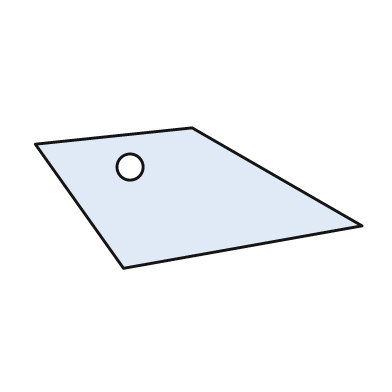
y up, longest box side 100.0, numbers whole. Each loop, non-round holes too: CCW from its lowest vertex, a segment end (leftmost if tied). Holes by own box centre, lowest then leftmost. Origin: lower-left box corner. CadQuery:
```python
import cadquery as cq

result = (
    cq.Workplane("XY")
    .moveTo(27.0, 0.0)
    .lineTo(100.0, 13.0)
    .lineTo(48.0, 43.0)
    .lineTo(0.0, 38.0)
    .close()
    .moveTo(29.0, 31.0)
    .circle(4.0)
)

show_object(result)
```